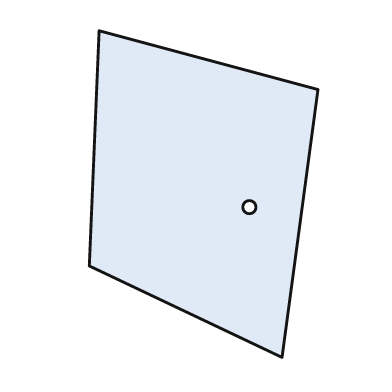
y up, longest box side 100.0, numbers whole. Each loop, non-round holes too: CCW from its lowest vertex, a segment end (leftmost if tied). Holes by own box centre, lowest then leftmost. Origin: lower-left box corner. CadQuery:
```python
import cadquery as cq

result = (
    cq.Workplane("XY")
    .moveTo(59.0, 0.0)
    .lineTo(70.0, 82.0)
    .lineTo(3.0, 100.0)
    .lineTo(0.0, 28.0)
    .close()
    .moveTo(49.0, 46.0)
    .circle(2.0)
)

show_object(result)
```